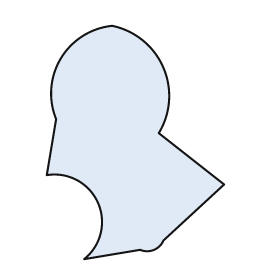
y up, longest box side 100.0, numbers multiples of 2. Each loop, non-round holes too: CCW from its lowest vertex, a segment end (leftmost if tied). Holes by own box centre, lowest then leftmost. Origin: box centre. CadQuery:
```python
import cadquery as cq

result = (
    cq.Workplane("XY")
    .moveTo(-22.0, -50.0)
    .lineTo(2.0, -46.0)
    .threePointArc((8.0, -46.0), (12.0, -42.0))
    .lineTo(38.0, -18.0)
    .lineTo(10.0, 4.0)
    .threePointArc((12.0, 32.0), (-10.0, 50.0))
    .threePointArc((-32.0, 36.0), (-34.0, 10.0))
    .lineTo(-38.0, -14.0)
    .threePointArc((-16.0, -26.0), (-22.0, -50.0))
    .close()
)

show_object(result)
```